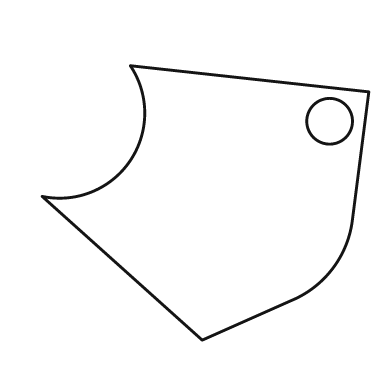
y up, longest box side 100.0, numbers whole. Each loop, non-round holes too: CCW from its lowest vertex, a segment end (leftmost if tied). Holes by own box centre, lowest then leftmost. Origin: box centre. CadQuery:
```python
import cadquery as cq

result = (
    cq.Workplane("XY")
    .moveTo(-1.0, -42.0)
    .lineTo(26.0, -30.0)
    .threePointArc((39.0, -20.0), (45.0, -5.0))
    .lineTo(50.0, 34.0)
    .lineTo(-23.0, 42.0)
    .threePointArc((-23.0, 13.0), (-50.0, 2.0))
    .close()
    .moveTo(38.0, 25.0)
    .circle(7.0)
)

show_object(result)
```